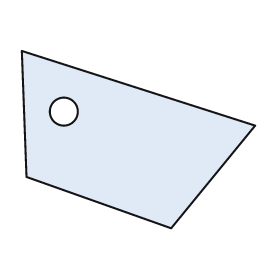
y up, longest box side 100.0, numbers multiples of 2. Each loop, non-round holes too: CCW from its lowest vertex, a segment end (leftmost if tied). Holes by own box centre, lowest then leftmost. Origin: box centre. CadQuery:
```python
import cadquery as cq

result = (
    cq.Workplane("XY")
    .moveTo(14.0, -38.0)
    .lineTo(50.0, 6.0)
    .lineTo(-50.0, 38.0)
    .lineTo(-48.0, -16.0)
    .close()
    .moveTo(-32.0, 12.0)
    .circle(6.0)
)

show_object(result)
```